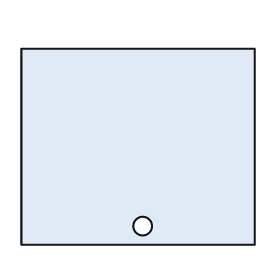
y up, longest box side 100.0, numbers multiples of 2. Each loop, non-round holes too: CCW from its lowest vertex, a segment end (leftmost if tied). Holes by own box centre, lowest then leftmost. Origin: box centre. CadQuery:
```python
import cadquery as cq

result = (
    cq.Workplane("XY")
    .moveTo(-50.0, -42.0)
    .lineTo(50.0, -42.0)
    .lineTo(50.0, 42.0)
    .lineTo(-50.0, 42.0)
    .close()
    .moveTo(2.0, -34.0)
    .circle(4.0)
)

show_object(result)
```